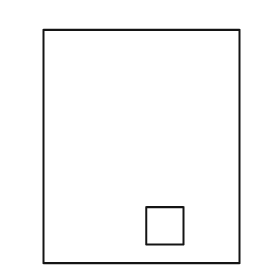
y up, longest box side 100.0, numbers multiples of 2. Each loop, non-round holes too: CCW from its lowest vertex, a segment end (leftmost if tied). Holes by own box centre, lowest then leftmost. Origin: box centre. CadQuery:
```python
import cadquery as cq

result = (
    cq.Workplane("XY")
    .moveTo(-42.0, -50.0)
    .lineTo(42.0, -50.0)
    .lineTo(42.0, 50.0)
    .lineTo(-42.0, 50.0)
    .close()
    .moveTo(2.0, -42.0)
    .lineTo(18.0, -42.0)
    .lineTo(18.0, -26.0)
    .lineTo(2.0, -26.0)
    .close()
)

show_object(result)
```